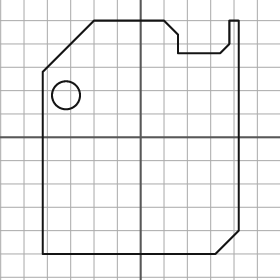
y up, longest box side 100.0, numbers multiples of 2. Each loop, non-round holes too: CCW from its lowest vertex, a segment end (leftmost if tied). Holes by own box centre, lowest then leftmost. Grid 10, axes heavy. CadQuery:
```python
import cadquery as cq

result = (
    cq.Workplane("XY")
    .moveTo(-42.0, -50.0)
    .lineTo(32.0, -50.0)
    .lineTo(42.0, -40.0)
    .lineTo(42.0, 50.0)
    .lineTo(38.0, 50.0)
    .lineTo(38.0, 40.0)
    .lineTo(34.0, 36.0)
    .lineTo(16.0, 36.0)
    .lineTo(16.0, 44.0)
    .lineTo(10.0, 50.0)
    .lineTo(-20.0, 50.0)
    .lineTo(-42.0, 28.0)
    .close()
    .moveTo(-32.0, 18.0)
    .circle(6.0)
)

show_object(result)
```